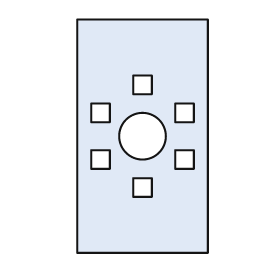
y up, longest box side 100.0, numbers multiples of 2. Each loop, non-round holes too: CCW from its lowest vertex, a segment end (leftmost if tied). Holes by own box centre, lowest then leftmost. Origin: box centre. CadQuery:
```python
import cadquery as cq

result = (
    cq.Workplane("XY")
    .moveTo(-28.0, -50.0)
    .lineTo(28.0, -50.0)
    .lineTo(28.0, 50.0)
    .lineTo(-28.0, 50.0)
    .close()
    .moveTo(-4.0, -26.0)
    .lineTo(4.0, -26.0)
    .lineTo(4.0, -18.0)
    .lineTo(-4.0, -18.0)
    .close()
    .moveTo(-22.0, -14.0)
    .lineTo(-14.0, -14.0)
    .lineTo(-14.0, -6.0)
    .lineTo(-22.0, -6.0)
    .close()
    .moveTo(14.0, -14.0)
    .lineTo(22.0, -14.0)
    .lineTo(22.0, -6.0)
    .lineTo(14.0, -6.0)
    .close()
    .moveTo(0.0, 0.0)
    .circle(10.0)
    .moveTo(-22.0, 6.0)
    .lineTo(-14.0, 6.0)
    .lineTo(-14.0, 14.0)
    .lineTo(-22.0, 14.0)
    .close()
    .moveTo(14.0, 6.0)
    .lineTo(22.0, 6.0)
    .lineTo(22.0, 14.0)
    .lineTo(14.0, 14.0)
    .close()
    .moveTo(-4.0, 18.0)
    .lineTo(4.0, 18.0)
    .lineTo(4.0, 26.0)
    .lineTo(-4.0, 26.0)
    .close()
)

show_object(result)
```